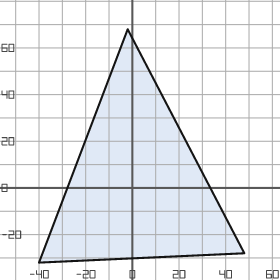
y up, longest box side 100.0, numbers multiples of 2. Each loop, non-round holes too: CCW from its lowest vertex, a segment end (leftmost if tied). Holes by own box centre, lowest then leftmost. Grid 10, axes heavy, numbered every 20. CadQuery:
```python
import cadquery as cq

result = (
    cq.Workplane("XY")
    .moveTo(-40.0, -32.0)
    .lineTo(48.0, -28.0)
    .lineTo(-2.0, 68.0)
    .close()
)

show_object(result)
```